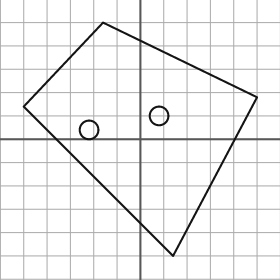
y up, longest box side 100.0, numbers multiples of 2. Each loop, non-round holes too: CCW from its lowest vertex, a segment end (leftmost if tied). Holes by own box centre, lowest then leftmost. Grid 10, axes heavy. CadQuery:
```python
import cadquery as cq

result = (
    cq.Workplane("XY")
    .moveTo(14.0, -50.0)
    .lineTo(50.0, 18.0)
    .lineTo(-16.0, 50.0)
    .lineTo(-50.0, 14.0)
    .close()
    .moveTo(-22.0, 4.0)
    .circle(4.0)
    .moveTo(8.0, 10.0)
    .circle(4.0)
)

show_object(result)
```